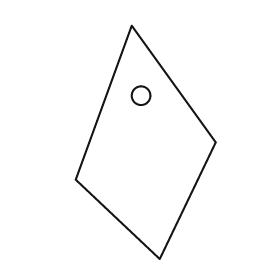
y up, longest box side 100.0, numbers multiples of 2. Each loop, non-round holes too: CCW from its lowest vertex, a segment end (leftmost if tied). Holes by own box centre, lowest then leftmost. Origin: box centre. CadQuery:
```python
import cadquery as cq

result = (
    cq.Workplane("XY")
    .moveTo(6.0, -50.0)
    .lineTo(30.0, 0.0)
    .lineTo(-6.0, 50.0)
    .lineTo(-30.0, -16.0)
    .close()
    .moveTo(-2.0, 20.0)
    .circle(4.0)
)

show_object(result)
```